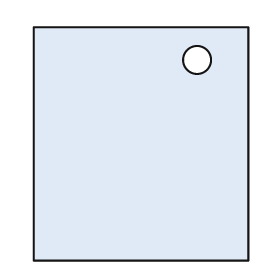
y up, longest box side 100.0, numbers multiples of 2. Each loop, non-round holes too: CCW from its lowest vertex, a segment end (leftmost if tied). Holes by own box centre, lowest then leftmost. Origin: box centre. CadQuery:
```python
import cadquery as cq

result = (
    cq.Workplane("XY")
    .moveTo(-46.0, -50.0)
    .lineTo(46.0, -50.0)
    .lineTo(46.0, 50.0)
    .lineTo(-46.0, 50.0)
    .close()
    .moveTo(24.0, 36.0)
    .circle(6.0)
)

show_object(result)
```